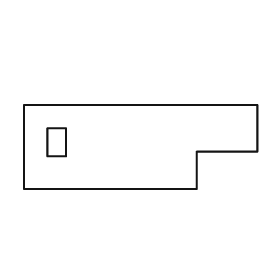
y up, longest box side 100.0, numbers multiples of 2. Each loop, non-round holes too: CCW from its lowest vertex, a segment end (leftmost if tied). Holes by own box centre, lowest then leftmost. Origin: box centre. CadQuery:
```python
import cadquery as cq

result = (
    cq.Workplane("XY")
    .moveTo(-50.0, -18.0)
    .lineTo(24.0, -18.0)
    .lineTo(24.0, -2.0)
    .lineTo(50.0, -2.0)
    .lineTo(50.0, 18.0)
    .lineTo(-50.0, 18.0)
    .close()
    .moveTo(-40.0, -4.0)
    .lineTo(-32.0, -4.0)
    .lineTo(-32.0, 8.0)
    .lineTo(-40.0, 8.0)
    .close()
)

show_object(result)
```